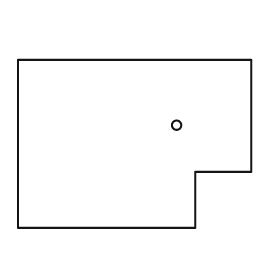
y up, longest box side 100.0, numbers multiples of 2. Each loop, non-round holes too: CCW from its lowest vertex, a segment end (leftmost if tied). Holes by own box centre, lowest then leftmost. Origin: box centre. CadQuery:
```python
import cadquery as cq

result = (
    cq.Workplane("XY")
    .moveTo(-50.0, -36.0)
    .lineTo(26.0, -36.0)
    .lineTo(26.0, -12.0)
    .lineTo(50.0, -12.0)
    .lineTo(50.0, 36.0)
    .lineTo(-50.0, 36.0)
    .close()
    .moveTo(18.0, 8.0)
    .circle(2.0)
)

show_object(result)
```